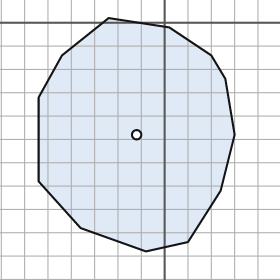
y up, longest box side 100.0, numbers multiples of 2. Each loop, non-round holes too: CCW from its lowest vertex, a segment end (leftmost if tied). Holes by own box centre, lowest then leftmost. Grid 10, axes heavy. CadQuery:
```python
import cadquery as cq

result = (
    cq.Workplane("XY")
    .moveTo(-8.0, -98.0)
    .lineTo(10.0, -94.0)
    .lineTo(24.0, -72.0)
    .lineTo(30.0, -48.0)
    .lineTo(26.0, -24.0)
    .lineTo(20.0, -14.0)
    .lineTo(2.0, -2.0)
    .lineTo(-24.0, 2.0)
    .lineTo(-44.0, -14.0)
    .lineTo(-54.0, -32.0)
    .lineTo(-54.0, -68.0)
    .lineTo(-36.0, -88.0)
    .close()
    .moveTo(-12.0, -48.0)
    .circle(2.0)
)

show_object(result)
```